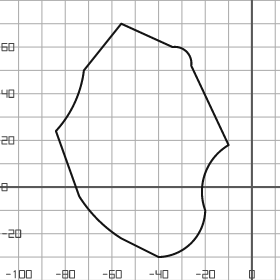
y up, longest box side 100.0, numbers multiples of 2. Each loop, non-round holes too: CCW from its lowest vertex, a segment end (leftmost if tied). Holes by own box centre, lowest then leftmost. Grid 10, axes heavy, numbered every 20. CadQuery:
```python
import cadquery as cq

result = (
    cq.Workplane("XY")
    .moveTo(-40.0, -30.0)
    .threePointArc((-26.0, -24.0), (-20.0, -10.0))
    .threePointArc((-20.0, 6.0), (-10.0, 18.0))
    .lineTo(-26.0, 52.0)
    .threePointArc((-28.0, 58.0), (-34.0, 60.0))
    .lineTo(-56.0, 70.0)
    .lineTo(-72.0, 50.0)
    .threePointArc((-76.0, 36.0), (-84.0, 24.0))
    .lineTo(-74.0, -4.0)
    .threePointArc((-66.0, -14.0), (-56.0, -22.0))
    .close()
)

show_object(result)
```